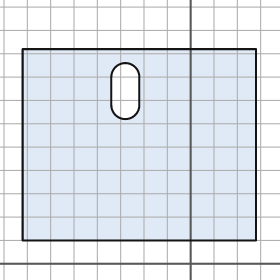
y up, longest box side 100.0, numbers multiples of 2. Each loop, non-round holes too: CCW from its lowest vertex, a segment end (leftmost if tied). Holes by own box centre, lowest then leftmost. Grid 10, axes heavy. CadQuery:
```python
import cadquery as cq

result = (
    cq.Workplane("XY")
    .moveTo(-72.0, 10.0)
    .lineTo(28.0, 10.0)
    .lineTo(28.0, 92.0)
    .lineTo(-72.0, 92.0)
    .close()
    .moveTo(-34.0, 68.0)
    .threePointArc((-28.0, 62.0), (-22.0, 68.0))
    .lineTo(-22.0, 80.0)
    .threePointArc((-28.0, 86.0), (-34.0, 80.0))
    .close()
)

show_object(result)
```